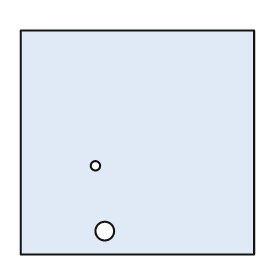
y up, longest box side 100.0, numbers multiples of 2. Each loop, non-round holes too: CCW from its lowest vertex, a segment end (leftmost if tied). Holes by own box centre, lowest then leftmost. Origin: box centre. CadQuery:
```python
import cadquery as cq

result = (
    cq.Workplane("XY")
    .moveTo(-50.0, -48.0)
    .lineTo(50.0, -48.0)
    .lineTo(50.0, 48.0)
    .lineTo(-50.0, 48.0)
    .close()
    .moveTo(-14.0, -38.0)
    .circle(4.0)
    .moveTo(-18.0, -10.0)
    .circle(2.0)
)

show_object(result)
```